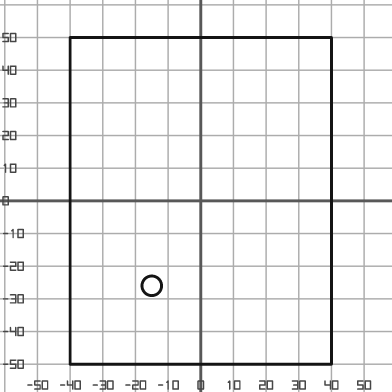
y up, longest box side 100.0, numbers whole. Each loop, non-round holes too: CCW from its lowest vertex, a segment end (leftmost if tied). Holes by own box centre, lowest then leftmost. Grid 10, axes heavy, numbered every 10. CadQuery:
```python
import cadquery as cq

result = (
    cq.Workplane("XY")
    .moveTo(-40.0, -50.0)
    .lineTo(40.0, -50.0)
    .lineTo(40.0, 50.0)
    .lineTo(-40.0, 50.0)
    .close()
    .moveTo(-15.0, -26.0)
    .circle(3.0)
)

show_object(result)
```